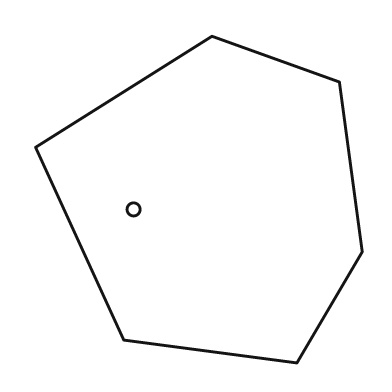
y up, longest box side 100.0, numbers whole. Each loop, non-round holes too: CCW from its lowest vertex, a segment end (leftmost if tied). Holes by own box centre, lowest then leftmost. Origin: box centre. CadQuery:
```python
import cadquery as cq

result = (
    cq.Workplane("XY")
    .moveTo(30.0, -50.0)
    .lineTo(50.0, -16.0)
    .lineTo(43.0, 36.0)
    .lineTo(4.0, 50.0)
    .lineTo(-50.0, 16.0)
    .lineTo(-23.0, -43.0)
    .close()
    .moveTo(-20.0, -3.0)
    .circle(2.0)
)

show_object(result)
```